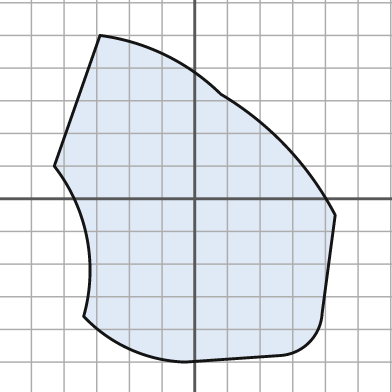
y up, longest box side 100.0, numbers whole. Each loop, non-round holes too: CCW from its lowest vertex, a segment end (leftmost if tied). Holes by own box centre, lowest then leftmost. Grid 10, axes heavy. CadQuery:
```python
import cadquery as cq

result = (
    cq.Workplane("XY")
    .moveTo(-3.0, -50.0)
    .lineTo(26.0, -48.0)
    .threePointArc((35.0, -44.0), (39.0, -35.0))
    .lineTo(43.0, -5.0)
    .threePointArc((28.0, 16.0), (8.0, 32.0))
    .threePointArc((-9.0, 44.0), (-29.0, 50.0))
    .lineTo(-43.0, 10.0)
    .threePointArc((-33.0, -12.0), (-34.0, -36.0))
    .threePointArc((-20.0, -46.0), (-3.0, -50.0))
    .close()
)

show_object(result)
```